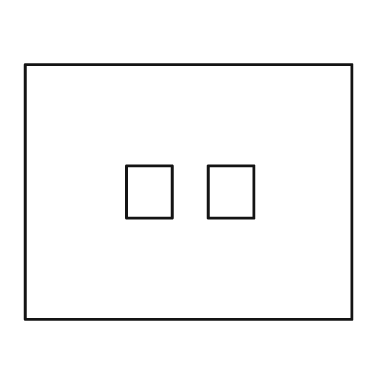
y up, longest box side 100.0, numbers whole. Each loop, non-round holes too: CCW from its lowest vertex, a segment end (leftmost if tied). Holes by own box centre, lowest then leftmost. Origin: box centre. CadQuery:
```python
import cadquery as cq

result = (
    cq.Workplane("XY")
    .moveTo(-50.0, -39.0)
    .lineTo(50.0, -39.0)
    .lineTo(50.0, 39.0)
    .lineTo(-50.0, 39.0)
    .close()
    .moveTo(-19.0, -8.0)
    .lineTo(-5.0, -8.0)
    .lineTo(-5.0, 8.0)
    .lineTo(-19.0, 8.0)
    .close()
    .moveTo(6.0, -8.0)
    .lineTo(20.0, -8.0)
    .lineTo(20.0, 8.0)
    .lineTo(6.0, 8.0)
    .close()
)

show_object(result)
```